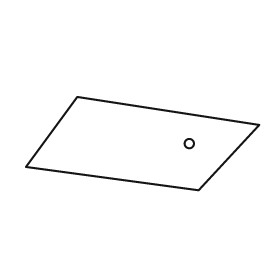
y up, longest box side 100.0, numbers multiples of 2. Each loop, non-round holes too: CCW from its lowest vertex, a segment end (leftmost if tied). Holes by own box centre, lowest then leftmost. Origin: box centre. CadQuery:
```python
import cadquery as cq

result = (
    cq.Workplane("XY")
    .moveTo(24.0, -20.0)
    .lineTo(50.0, 8.0)
    .lineTo(-28.0, 20.0)
    .lineTo(-50.0, -10.0)
    .close()
    .moveTo(20.0, 0.0)
    .circle(2.0)
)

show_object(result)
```